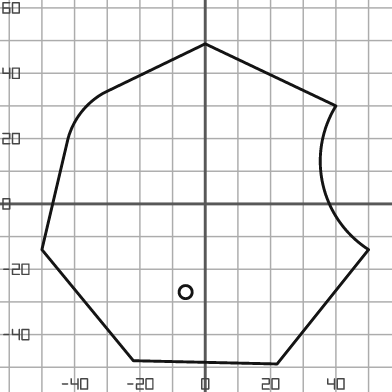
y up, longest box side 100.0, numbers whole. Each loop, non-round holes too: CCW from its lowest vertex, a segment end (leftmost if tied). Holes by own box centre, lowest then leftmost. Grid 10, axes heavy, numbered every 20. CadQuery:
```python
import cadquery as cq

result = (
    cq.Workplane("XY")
    .moveTo(22.0, -49.0)
    .lineTo(50.0, -14.0)
    .threePointArc((36.0, 6.0), (40.0, 30.0))
    .lineTo(0.0, 49.0)
    .lineTo(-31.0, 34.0)
    .threePointArc((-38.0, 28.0), (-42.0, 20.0))
    .lineTo(-50.0, -14.0)
    .lineTo(-22.0, -48.0)
    .close()
    .moveTo(-6.0, -27.0)
    .circle(2.0)
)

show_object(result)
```